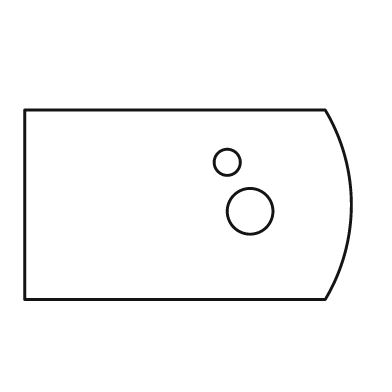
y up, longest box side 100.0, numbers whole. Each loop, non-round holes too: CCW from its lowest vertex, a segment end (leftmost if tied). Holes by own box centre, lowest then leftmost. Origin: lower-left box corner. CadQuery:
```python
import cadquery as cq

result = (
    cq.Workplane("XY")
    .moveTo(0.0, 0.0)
    .lineTo(92.0, 0.0)
    .threePointArc((100.0, 29.0), (92.0, 58.0))
    .lineTo(0.0, 58.0)
    .close()
    .moveTo(69.0, 27.0)
    .circle(7.0)
    .moveTo(62.0, 42.0)
    .circle(4.0)
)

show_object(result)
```